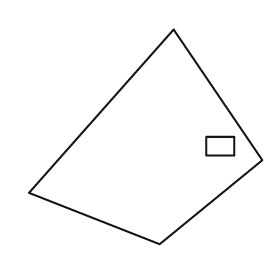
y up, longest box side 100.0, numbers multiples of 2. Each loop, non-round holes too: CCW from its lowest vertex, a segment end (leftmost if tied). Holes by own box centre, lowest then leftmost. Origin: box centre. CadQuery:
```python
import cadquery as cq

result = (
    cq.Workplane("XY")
    .moveTo(6.0, -46.0)
    .lineTo(50.0, -10.0)
    .lineTo(12.0, 46.0)
    .lineTo(-50.0, -24.0)
    .close()
    .moveTo(26.0, -8.0)
    .lineTo(38.0, -8.0)
    .lineTo(38.0, 0.0)
    .lineTo(26.0, 0.0)
    .close()
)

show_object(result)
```